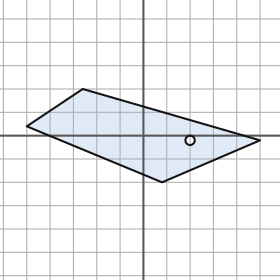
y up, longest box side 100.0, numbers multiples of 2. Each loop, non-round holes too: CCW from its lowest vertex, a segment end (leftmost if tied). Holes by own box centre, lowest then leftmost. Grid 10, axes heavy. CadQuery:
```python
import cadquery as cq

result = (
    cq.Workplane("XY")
    .moveTo(8.0, -20.0)
    .lineTo(50.0, -2.0)
    .lineTo(-26.0, 20.0)
    .lineTo(-50.0, 4.0)
    .close()
    .moveTo(20.0, -2.0)
    .circle(2.0)
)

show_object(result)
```